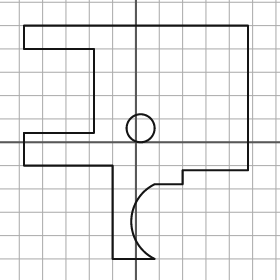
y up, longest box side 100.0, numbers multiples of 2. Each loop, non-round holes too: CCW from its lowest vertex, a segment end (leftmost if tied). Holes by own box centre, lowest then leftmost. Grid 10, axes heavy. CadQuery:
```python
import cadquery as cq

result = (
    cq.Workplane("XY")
    .moveTo(-10.0, -50.0)
    .lineTo(8.0, -50.0)
    .threePointArc((-2.0, -34.0), (8.0, -18.0))
    .lineTo(20.0, -18.0)
    .lineTo(20.0, -12.0)
    .lineTo(48.0, -12.0)
    .lineTo(48.0, 50.0)
    .lineTo(-48.0, 50.0)
    .lineTo(-48.0, 40.0)
    .lineTo(-18.0, 40.0)
    .lineTo(-18.0, 4.0)
    .lineTo(-48.0, 4.0)
    .lineTo(-48.0, -10.0)
    .lineTo(-10.0, -10.0)
    .close()
    .moveTo(2.0, 6.0)
    .circle(6.0)
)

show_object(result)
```